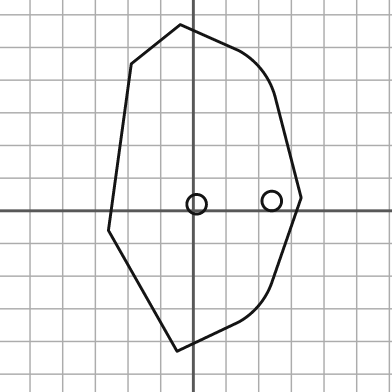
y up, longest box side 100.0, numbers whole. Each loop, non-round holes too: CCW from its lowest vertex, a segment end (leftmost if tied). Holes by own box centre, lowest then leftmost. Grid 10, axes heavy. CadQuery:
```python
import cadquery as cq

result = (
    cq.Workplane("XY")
    .moveTo(-5.0, -43.0)
    .lineTo(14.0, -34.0)
    .threePointArc((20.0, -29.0), (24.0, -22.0))
    .lineTo(33.0, 4.0)
    .lineTo(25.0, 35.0)
    .threePointArc((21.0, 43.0), (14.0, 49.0))
    .lineTo(-4.0, 57.0)
    .lineTo(-19.0, 45.0)
    .lineTo(-26.0, -6.0)
    .close()
    .moveTo(1.0, 2.0)
    .circle(3.0)
    .moveTo(24.0, 3.0)
    .circle(3.0)
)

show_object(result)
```